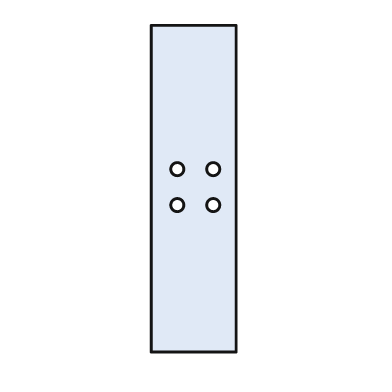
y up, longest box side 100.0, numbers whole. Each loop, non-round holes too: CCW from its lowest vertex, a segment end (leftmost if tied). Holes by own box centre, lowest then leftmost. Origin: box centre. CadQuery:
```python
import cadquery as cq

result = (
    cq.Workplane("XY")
    .moveTo(-13.0, -50.0)
    .lineTo(13.0, -50.0)
    .lineTo(13.0, 50.0)
    .lineTo(-13.0, 50.0)
    .close()
    .moveTo(-5.0, -5.0)
    .circle(2.0)
    .moveTo(6.0, -5.0)
    .circle(2.0)
    .moveTo(-5.0, 6.0)
    .circle(2.0)
    .moveTo(6.0, 6.0)
    .circle(2.0)
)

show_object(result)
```